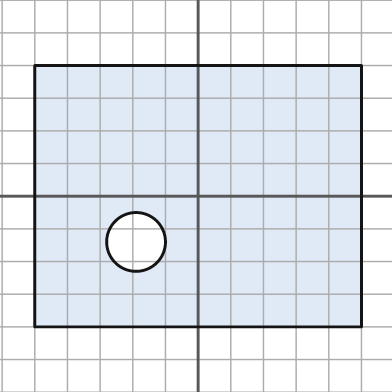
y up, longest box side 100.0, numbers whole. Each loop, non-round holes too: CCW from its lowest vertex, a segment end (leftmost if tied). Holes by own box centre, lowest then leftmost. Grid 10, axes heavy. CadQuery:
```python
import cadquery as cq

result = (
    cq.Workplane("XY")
    .moveTo(-50.0, -40.0)
    .lineTo(50.0, -40.0)
    .lineTo(50.0, 40.0)
    .lineTo(-50.0, 40.0)
    .close()
    .moveTo(-19.0, -14.0)
    .circle(9.0)
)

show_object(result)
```